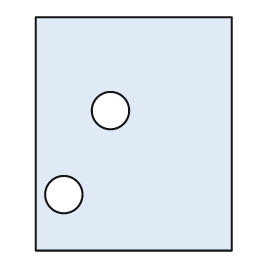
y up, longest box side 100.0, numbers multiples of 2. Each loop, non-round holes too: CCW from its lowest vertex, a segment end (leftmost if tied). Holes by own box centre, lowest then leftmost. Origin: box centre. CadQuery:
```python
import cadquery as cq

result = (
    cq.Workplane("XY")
    .moveTo(-42.0, -50.0)
    .lineTo(42.0, -50.0)
    .lineTo(42.0, 50.0)
    .lineTo(-42.0, 50.0)
    .close()
    .moveTo(-30.0, -26.0)
    .circle(8.0)
    .moveTo(-10.0, 10.0)
    .circle(8.0)
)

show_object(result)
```